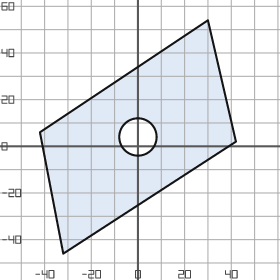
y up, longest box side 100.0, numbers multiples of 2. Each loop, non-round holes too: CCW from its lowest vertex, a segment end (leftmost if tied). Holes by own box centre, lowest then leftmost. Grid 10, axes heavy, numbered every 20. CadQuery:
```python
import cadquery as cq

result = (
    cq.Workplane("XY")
    .moveTo(-32.0, -46.0)
    .lineTo(42.0, 2.0)
    .lineTo(30.0, 54.0)
    .lineTo(-42.0, 6.0)
    .close()
    .moveTo(0.0, 4.0)
    .circle(8.0)
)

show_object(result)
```